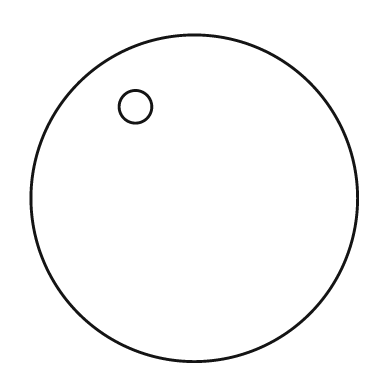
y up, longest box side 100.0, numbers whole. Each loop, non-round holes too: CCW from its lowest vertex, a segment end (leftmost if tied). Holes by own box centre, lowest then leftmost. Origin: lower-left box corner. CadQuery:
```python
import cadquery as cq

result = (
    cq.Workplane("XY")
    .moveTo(50.0, 50.0)
    .circle(50.0)
    .moveTo(32.0, 78.0)
    .circle(5.0)
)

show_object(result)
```